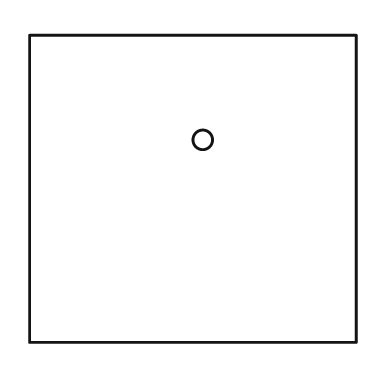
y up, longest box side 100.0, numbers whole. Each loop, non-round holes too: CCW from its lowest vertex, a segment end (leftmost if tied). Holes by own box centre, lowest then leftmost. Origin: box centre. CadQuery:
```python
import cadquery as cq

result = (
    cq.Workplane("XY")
    .moveTo(-50.0, -47.0)
    .lineTo(50.0, -47.0)
    .lineTo(50.0, 47.0)
    .lineTo(-50.0, 47.0)
    .close()
    .moveTo(3.0, 15.0)
    .circle(3.0)
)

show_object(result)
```